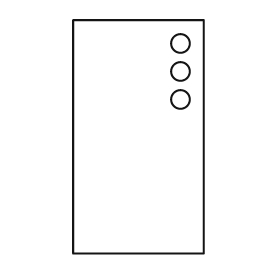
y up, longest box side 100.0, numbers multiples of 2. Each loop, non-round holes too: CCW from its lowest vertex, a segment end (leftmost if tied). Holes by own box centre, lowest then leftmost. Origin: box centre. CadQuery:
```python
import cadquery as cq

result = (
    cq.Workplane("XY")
    .moveTo(-28.0, -50.0)
    .lineTo(28.0, -50.0)
    .lineTo(28.0, 50.0)
    .lineTo(-28.0, 50.0)
    .close()
    .moveTo(18.0, 16.0)
    .circle(4.0)
    .moveTo(18.0, 28.0)
    .circle(4.0)
    .moveTo(18.0, 40.0)
    .circle(4.0)
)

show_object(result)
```